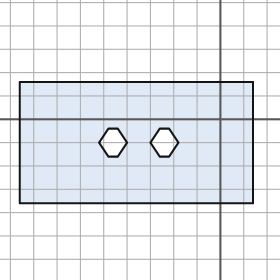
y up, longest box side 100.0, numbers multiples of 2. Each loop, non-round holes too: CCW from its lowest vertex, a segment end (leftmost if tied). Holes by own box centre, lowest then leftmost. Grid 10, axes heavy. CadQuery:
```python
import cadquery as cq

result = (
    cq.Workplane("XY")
    .moveTo(-86.0, -36.0)
    .lineTo(14.0, -36.0)
    .lineTo(14.0, 16.0)
    .lineTo(-86.0, 16.0)
    .close()
    .moveTo(-48.0, -16.0)
    .lineTo(-44.0, -16.0)
    .lineTo(-40.0, -10.0)
    .lineTo(-44.0, -4.0)
    .lineTo(-48.0, -4.0)
    .lineTo(-52.0, -10.0)
    .close()
    .moveTo(-26.0, -16.0)
    .lineTo(-22.0, -16.0)
    .lineTo(-18.0, -10.0)
    .lineTo(-22.0, -4.0)
    .lineTo(-26.0, -4.0)
    .lineTo(-30.0, -10.0)
    .close()
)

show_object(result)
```